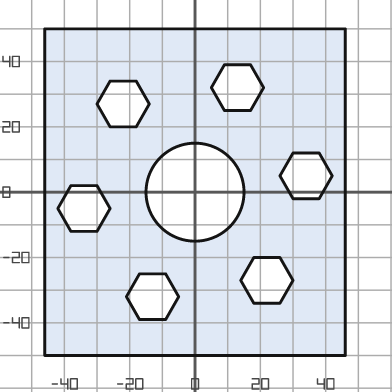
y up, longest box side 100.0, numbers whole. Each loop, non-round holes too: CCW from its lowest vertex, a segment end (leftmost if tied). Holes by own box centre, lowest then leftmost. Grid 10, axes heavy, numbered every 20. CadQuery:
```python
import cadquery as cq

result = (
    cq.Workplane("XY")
    .moveTo(-46.0, -50.0)
    .lineTo(46.0, -50.0)
    .lineTo(46.0, 50.0)
    .lineTo(-46.0, 50.0)
    .close()
    .moveTo(-17.0, -39.0)
    .lineTo(-9.0, -39.0)
    .lineTo(-5.0, -32.0)
    .lineTo(-9.0, -25.0)
    .lineTo(-17.0, -25.0)
    .lineTo(-21.0, -32.0)
    .close()
    .moveTo(18.0, -34.0)
    .lineTo(26.0, -34.0)
    .lineTo(30.0, -27.0)
    .lineTo(26.0, -20.0)
    .lineTo(18.0, -20.0)
    .lineTo(14.0, -27.0)
    .close()
    .moveTo(-38.0, -12.0)
    .lineTo(-30.0, -12.0)
    .lineTo(-26.0, -5.0)
    .lineTo(-30.0, 2.0)
    .lineTo(-38.0, 2.0)
    .lineTo(-42.0, -5.0)
    .close()
    .moveTo(0.0, 0.0)
    .circle(15.0)
    .moveTo(30.0, -2.0)
    .lineTo(38.0, -2.0)
    .lineTo(42.0, 5.0)
    .lineTo(38.0, 12.0)
    .lineTo(30.0, 12.0)
    .lineTo(26.0, 5.0)
    .close()
    .moveTo(-26.0, 20.0)
    .lineTo(-18.0, 20.0)
    .lineTo(-14.0, 27.0)
    .lineTo(-18.0, 34.0)
    .lineTo(-26.0, 34.0)
    .lineTo(-30.0, 27.0)
    .close()
    .moveTo(9.0, 25.0)
    .lineTo(17.0, 25.0)
    .lineTo(21.0, 32.0)
    .lineTo(17.0, 39.0)
    .lineTo(9.0, 39.0)
    .lineTo(5.0, 32.0)
    .close()
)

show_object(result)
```